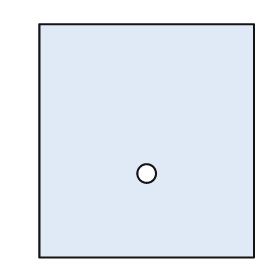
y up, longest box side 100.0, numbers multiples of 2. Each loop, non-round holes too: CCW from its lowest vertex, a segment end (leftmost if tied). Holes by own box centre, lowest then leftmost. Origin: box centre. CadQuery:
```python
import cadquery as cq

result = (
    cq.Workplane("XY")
    .moveTo(-46.0, -50.0)
    .lineTo(46.0, -50.0)
    .lineTo(46.0, 50.0)
    .lineTo(-46.0, 50.0)
    .close()
    .moveTo(0.0, -14.0)
    .circle(4.0)
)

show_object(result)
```